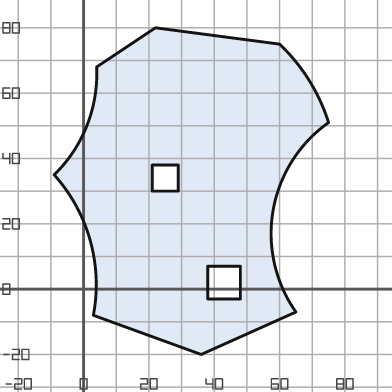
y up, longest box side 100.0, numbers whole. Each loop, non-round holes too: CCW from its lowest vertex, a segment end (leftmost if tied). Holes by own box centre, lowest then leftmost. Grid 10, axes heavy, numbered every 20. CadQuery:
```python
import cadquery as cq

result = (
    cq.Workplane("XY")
    .moveTo(36.0, -20.0)
    .lineTo(65.0, -7.0)
    .threePointArc((58.0, 24.0), (75.0, 51.0))
    .threePointArc((69.0, 64.0), (60.0, 75.0))
    .lineTo(22.0, 80.0)
    .lineTo(4.0, 68.0)
    .threePointArc((1.0, 50.0), (-9.0, 35.0))
    .threePointArc((2.0, 15.0), (3.0, -8.0))
    .close()
    .moveTo(38.0, -3.0)
    .lineTo(48.0, -3.0)
    .lineTo(48.0, 7.0)
    .lineTo(38.0, 7.0)
    .close()
    .moveTo(21.0, 30.0)
    .lineTo(29.0, 30.0)
    .lineTo(29.0, 38.0)
    .lineTo(21.0, 38.0)
    .close()
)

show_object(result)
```